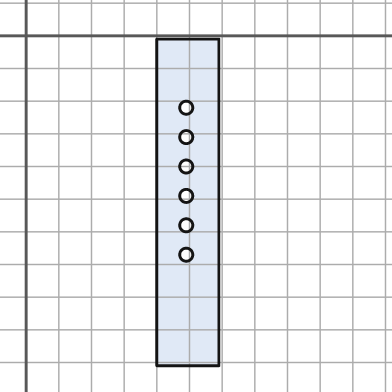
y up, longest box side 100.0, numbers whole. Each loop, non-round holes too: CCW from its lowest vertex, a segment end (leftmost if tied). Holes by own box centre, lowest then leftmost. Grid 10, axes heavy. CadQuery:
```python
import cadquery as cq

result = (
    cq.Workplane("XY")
    .moveTo(40.0, -101.0)
    .lineTo(59.0, -101.0)
    .lineTo(59.0, -1.0)
    .lineTo(40.0, -1.0)
    .close()
    .moveTo(49.0, -67.0)
    .circle(2.0)
    .moveTo(49.0, -58.0)
    .circle(2.0)
    .moveTo(49.0, -49.0)
    .circle(2.0)
    .moveTo(49.0, -40.0)
    .circle(2.0)
    .moveTo(49.0, -31.0)
    .circle(2.0)
    .moveTo(49.0, -22.0)
    .circle(2.0)
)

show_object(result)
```